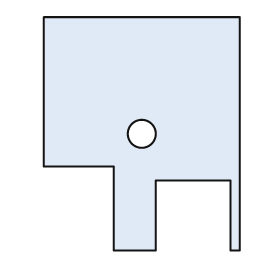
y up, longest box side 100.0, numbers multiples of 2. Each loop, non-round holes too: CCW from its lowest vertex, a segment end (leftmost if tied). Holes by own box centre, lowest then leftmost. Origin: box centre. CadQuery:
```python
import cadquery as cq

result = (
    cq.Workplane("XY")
    .moveTo(-12.0, -50.0)
    .lineTo(6.0, -50.0)
    .lineTo(6.0, -20.0)
    .lineTo(38.0, -20.0)
    .lineTo(38.0, -50.0)
    .lineTo(42.0, -50.0)
    .lineTo(42.0, 50.0)
    .lineTo(-42.0, 50.0)
    .lineTo(-42.0, -14.0)
    .lineTo(-12.0, -14.0)
    .close()
    .moveTo(0.0, 0.0)
    .circle(6.0)
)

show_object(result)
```